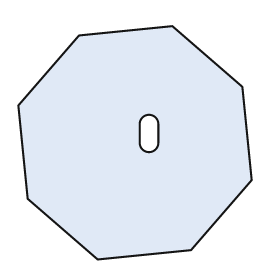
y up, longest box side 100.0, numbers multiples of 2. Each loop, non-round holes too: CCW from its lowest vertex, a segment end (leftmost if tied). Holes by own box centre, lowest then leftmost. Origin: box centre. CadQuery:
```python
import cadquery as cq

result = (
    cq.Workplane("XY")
    .moveTo(-16.0, -50.0)
    .lineTo(24.0, -46.0)
    .lineTo(50.0, -16.0)
    .lineTo(46.0, 24.0)
    .lineTo(16.0, 50.0)
    .lineTo(-24.0, 46.0)
    .lineTo(-50.0, 16.0)
    .lineTo(-46.0, -24.0)
    .close()
    .moveTo(2.0, 0.0)
    .threePointArc((6.0, -4.0), (10.0, 0.0))
    .lineTo(10.0, 8.0)
    .threePointArc((6.0, 12.0), (2.0, 8.0))
    .close()
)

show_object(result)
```